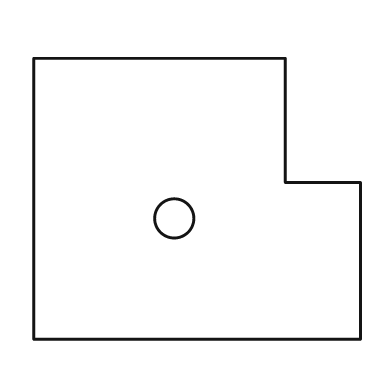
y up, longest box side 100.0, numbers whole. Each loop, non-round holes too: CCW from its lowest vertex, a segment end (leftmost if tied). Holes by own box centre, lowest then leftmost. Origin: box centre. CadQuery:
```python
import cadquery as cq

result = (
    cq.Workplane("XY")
    .moveTo(-50.0, -43.0)
    .lineTo(50.0, -43.0)
    .lineTo(50.0, 5.0)
    .lineTo(27.0, 5.0)
    .lineTo(27.0, 43.0)
    .lineTo(-50.0, 43.0)
    .close()
    .moveTo(-7.0, -6.0)
    .circle(6.0)
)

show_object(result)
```